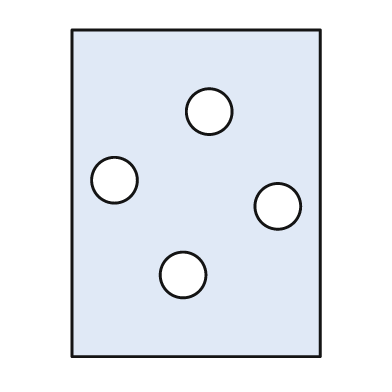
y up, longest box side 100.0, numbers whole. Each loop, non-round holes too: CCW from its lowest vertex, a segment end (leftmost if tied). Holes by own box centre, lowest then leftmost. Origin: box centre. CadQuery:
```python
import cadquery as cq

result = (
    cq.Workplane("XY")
    .moveTo(-38.0, -50.0)
    .lineTo(38.0, -50.0)
    .lineTo(38.0, 50.0)
    .lineTo(-38.0, 50.0)
    .close()
    .moveTo(-4.0, -25.0)
    .circle(7.0)
    .moveTo(25.0, -4.0)
    .circle(7.0)
    .moveTo(-25.0, 4.0)
    .circle(7.0)
    .moveTo(4.0, 25.0)
    .circle(7.0)
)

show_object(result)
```